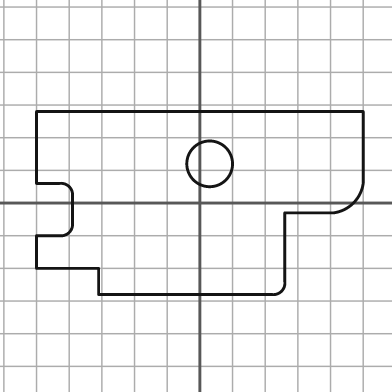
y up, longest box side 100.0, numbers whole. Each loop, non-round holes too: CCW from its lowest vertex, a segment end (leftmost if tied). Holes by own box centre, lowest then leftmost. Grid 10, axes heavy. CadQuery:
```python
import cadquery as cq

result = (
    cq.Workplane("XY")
    .moveTo(-31.0, -28.0)
    .lineTo(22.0, -28.0)
    .threePointArc((25.0, -27.0), (26.0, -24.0))
    .lineTo(26.0, -3.0)
    .lineTo(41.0, -3.0)
    .threePointArc((47.0, 0.0), (50.0, 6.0))
    .lineTo(50.0, 28.0)
    .lineTo(-50.0, 28.0)
    .lineTo(-50.0, 6.0)
    .lineTo(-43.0, 6.0)
    .threePointArc((-40.0, 5.0), (-39.0, 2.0))
    .lineTo(-39.0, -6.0)
    .threePointArc((-40.0, -9.0), (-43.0, -10.0))
    .lineTo(-50.0, -10.0)
    .lineTo(-50.0, -20.0)
    .lineTo(-31.0, -20.0)
    .close()
    .moveTo(3.0, 12.0)
    .circle(7.0)
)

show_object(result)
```